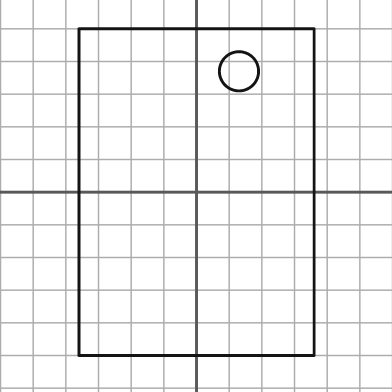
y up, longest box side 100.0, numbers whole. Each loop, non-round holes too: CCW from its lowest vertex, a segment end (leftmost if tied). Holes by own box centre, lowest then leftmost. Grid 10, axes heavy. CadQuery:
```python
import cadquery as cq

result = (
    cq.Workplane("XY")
    .moveTo(-36.0, -50.0)
    .lineTo(36.0, -50.0)
    .lineTo(36.0, 50.0)
    .lineTo(-36.0, 50.0)
    .close()
    .moveTo(13.0, 37.0)
    .circle(6.0)
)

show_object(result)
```